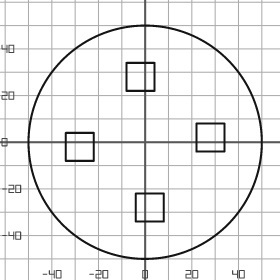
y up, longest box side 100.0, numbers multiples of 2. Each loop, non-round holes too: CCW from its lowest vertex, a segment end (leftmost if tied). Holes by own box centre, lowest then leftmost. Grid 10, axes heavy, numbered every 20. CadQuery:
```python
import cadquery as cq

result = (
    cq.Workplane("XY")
    .moveTo(0.0, 0.0)
    .circle(50.0)
    .moveTo(-4.0, -34.0)
    .lineTo(8.0, -34.0)
    .lineTo(8.0, -22.0)
    .lineTo(-4.0, -22.0)
    .close()
    .moveTo(-34.0, -8.0)
    .lineTo(-22.0, -8.0)
    .lineTo(-22.0, 4.0)
    .lineTo(-34.0, 4.0)
    .close()
    .moveTo(22.0, -4.0)
    .lineTo(34.0, -4.0)
    .lineTo(34.0, 8.0)
    .lineTo(22.0, 8.0)
    .close()
    .moveTo(-8.0, 22.0)
    .lineTo(4.0, 22.0)
    .lineTo(4.0, 34.0)
    .lineTo(-8.0, 34.0)
    .close()
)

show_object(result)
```